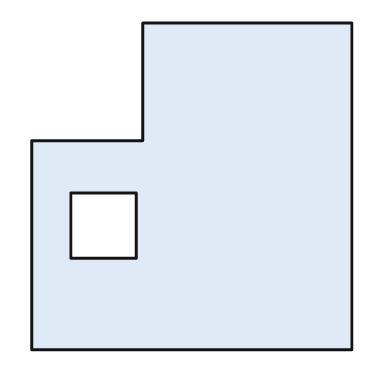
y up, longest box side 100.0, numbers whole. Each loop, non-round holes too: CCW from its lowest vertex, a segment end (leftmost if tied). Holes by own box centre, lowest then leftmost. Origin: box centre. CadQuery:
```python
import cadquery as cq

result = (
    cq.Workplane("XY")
    .moveTo(-49.0, -50.0)
    .lineTo(49.0, -50.0)
    .lineTo(49.0, 50.0)
    .lineTo(-15.0, 50.0)
    .lineTo(-15.0, 14.0)
    .lineTo(-49.0, 14.0)
    .close()
    .moveTo(-37.0, -22.0)
    .lineTo(-17.0, -22.0)
    .lineTo(-17.0, -2.0)
    .lineTo(-37.0, -2.0)
    .close()
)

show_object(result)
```